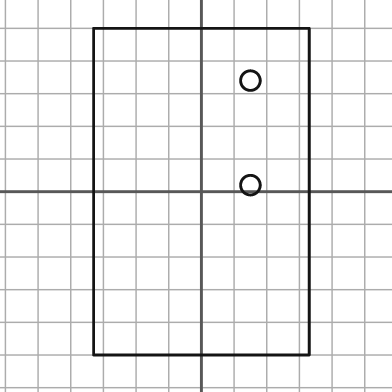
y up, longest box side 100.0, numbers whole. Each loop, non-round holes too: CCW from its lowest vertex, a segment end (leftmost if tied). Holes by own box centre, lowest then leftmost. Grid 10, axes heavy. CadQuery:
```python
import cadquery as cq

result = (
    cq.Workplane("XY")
    .moveTo(-33.0, -50.0)
    .lineTo(33.0, -50.0)
    .lineTo(33.0, 50.0)
    .lineTo(-33.0, 50.0)
    .close()
    .moveTo(15.0, 2.0)
    .circle(3.0)
    .moveTo(15.0, 34.0)
    .circle(3.0)
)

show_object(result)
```